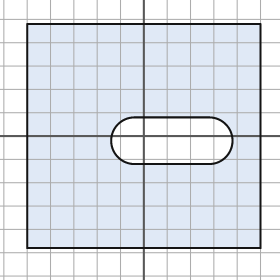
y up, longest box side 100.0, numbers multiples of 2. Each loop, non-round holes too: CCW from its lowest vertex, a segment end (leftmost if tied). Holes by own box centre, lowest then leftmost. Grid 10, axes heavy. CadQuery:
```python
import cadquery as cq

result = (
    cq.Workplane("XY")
    .moveTo(-50.0, -48.0)
    .lineTo(50.0, -48.0)
    .lineTo(50.0, 48.0)
    .lineTo(-50.0, 48.0)
    .close()
    .moveTo(-4.0, -12.0)
    .lineTo(28.0, -12.0)
    .threePointArc((38.0, -2.0), (28.0, 8.0))
    .lineTo(-4.0, 8.0)
    .threePointArc((-14.0, -2.0), (-4.0, -12.0))
    .close()
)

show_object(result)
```